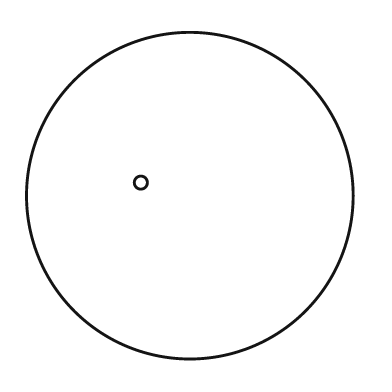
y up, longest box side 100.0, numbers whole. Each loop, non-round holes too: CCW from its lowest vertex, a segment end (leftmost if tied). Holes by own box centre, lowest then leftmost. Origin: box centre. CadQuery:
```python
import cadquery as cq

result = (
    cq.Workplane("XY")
    .moveTo(0.0, 0.0)
    .circle(50.0)
    .moveTo(-15.0, 4.0)
    .circle(2.0)
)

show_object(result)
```